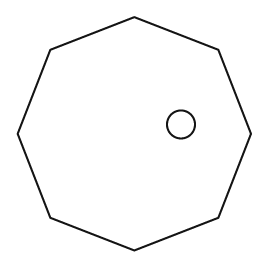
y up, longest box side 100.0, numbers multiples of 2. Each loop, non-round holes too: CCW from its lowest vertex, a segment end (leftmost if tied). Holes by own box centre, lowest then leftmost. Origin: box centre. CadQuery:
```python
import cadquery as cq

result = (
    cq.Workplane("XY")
    .moveTo(0.0, -50.0)
    .lineTo(36.0, -36.0)
    .lineTo(50.0, 0.0)
    .lineTo(36.0, 36.0)
    .lineTo(0.0, 50.0)
    .lineTo(-36.0, 36.0)
    .lineTo(-50.0, 0.0)
    .lineTo(-36.0, -36.0)
    .close()
    .moveTo(20.0, 4.0)
    .circle(6.0)
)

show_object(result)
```